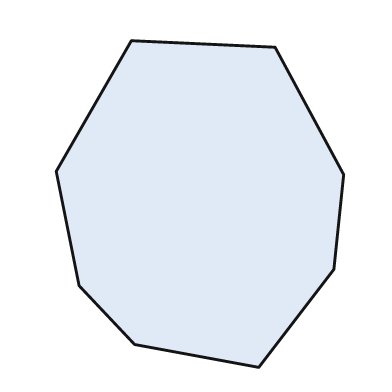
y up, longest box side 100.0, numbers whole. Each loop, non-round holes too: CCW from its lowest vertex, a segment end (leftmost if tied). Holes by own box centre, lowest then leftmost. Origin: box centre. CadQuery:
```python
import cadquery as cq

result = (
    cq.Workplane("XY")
    .moveTo(18.0, -50.0)
    .lineTo(41.0, -20.0)
    .lineTo(44.0, 9.0)
    .lineTo(23.0, 48.0)
    .lineTo(-21.0, 50.0)
    .lineTo(-44.0, 10.0)
    .lineTo(-37.0, -25.0)
    .lineTo(-20.0, -43.0)
    .close()
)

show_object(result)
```